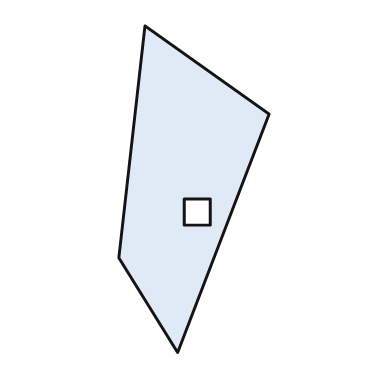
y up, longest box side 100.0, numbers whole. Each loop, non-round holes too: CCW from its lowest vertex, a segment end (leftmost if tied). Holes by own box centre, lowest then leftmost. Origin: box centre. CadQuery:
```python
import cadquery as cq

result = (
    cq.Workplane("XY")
    .moveTo(-5.0, -50.0)
    .lineTo(23.0, 23.0)
    .lineTo(-15.0, 50.0)
    .lineTo(-23.0, -21.0)
    .close()
    .moveTo(-3.0, -11.0)
    .lineTo(5.0, -11.0)
    .lineTo(5.0, -3.0)
    .lineTo(-3.0, -3.0)
    .close()
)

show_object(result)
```